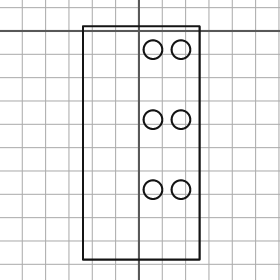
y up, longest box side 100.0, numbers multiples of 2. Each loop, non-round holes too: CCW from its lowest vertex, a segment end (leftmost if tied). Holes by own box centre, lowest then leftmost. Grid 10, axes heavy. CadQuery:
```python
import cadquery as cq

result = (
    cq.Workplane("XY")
    .moveTo(-24.0, -98.0)
    .lineTo(26.0, -98.0)
    .lineTo(26.0, 2.0)
    .lineTo(-24.0, 2.0)
    .close()
    .moveTo(6.0, -68.0)
    .circle(4.0)
    .moveTo(18.0, -68.0)
    .circle(4.0)
    .moveTo(6.0, -38.0)
    .circle(4.0)
    .moveTo(18.0, -38.0)
    .circle(4.0)
    .moveTo(6.0, -8.0)
    .circle(4.0)
    .moveTo(18.0, -8.0)
    .circle(4.0)
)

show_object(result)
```